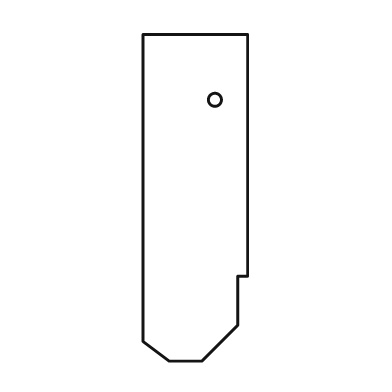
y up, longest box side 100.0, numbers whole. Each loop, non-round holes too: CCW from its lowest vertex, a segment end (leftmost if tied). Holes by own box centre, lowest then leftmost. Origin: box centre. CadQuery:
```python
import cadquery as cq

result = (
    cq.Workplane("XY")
    .moveTo(-8.0, -50.0)
    .lineTo(2.0, -50.0)
    .lineTo(13.0, -39.0)
    .lineTo(13.0, -24.0)
    .lineTo(16.0, -24.0)
    .lineTo(16.0, 50.0)
    .lineTo(-16.0, 50.0)
    .lineTo(-16.0, -44.0)
    .close()
    .moveTo(6.0, 30.0)
    .circle(2.0)
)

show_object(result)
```